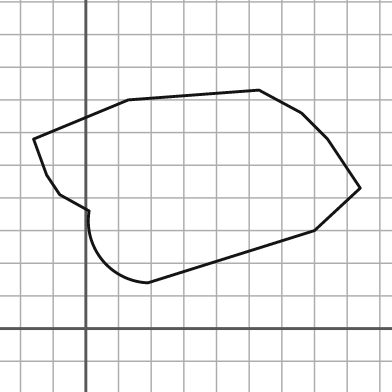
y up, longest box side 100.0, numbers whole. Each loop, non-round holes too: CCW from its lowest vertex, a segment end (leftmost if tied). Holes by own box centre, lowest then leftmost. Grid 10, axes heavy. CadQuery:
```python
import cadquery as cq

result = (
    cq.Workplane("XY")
    .moveTo(19.0, 14.0)
    .lineTo(70.0, 30.0)
    .lineTo(84.0, 43.0)
    .lineTo(74.0, 58.0)
    .lineTo(66.0, 66.0)
    .lineTo(53.0, 73.0)
    .lineTo(13.0, 70.0)
    .lineTo(-16.0, 58.0)
    .lineTo(-12.0, 47.0)
    .lineTo(-8.0, 41.0)
    .lineTo(1.0, 36.0)
    .threePointArc((5.0, 21.0), (19.0, 14.0))
    .close()
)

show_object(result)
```